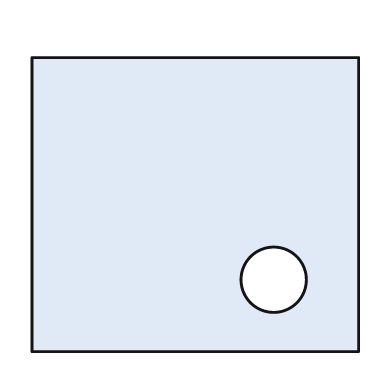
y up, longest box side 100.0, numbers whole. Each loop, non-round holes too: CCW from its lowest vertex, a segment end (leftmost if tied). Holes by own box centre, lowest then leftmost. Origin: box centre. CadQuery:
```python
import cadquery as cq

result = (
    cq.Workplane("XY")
    .moveTo(-50.0, -45.0)
    .lineTo(50.0, -45.0)
    .lineTo(50.0, 45.0)
    .lineTo(-50.0, 45.0)
    .close()
    .moveTo(24.0, -23.0)
    .circle(10.0)
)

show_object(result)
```